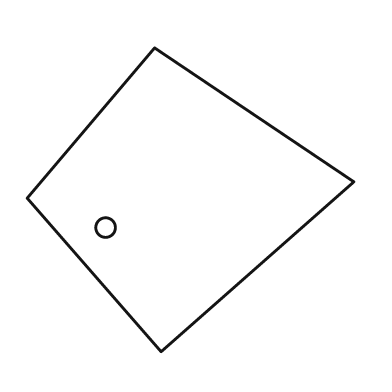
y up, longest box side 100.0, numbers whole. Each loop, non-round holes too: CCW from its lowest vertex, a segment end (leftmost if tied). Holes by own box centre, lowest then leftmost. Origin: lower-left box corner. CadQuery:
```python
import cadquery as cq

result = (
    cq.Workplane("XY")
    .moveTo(41.0, 0.0)
    .lineTo(100.0, 52.0)
    .lineTo(39.0, 93.0)
    .lineTo(0.0, 47.0)
    .close()
    .moveTo(24.0, 38.0)
    .circle(3.0)
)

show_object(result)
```